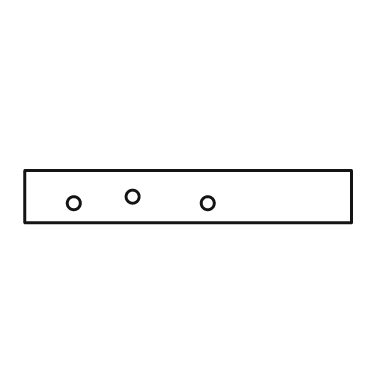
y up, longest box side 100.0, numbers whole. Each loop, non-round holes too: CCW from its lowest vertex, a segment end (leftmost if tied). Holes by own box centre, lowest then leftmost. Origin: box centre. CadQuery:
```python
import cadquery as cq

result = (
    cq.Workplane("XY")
    .moveTo(-50.0, -8.0)
    .lineTo(50.0, -8.0)
    .lineTo(50.0, 8.0)
    .lineTo(-50.0, 8.0)
    .close()
    .moveTo(-35.0, -2.0)
    .circle(2.0)
    .moveTo(6.0, -2.0)
    .circle(2.0)
    .moveTo(-17.0, 0.0)
    .circle(2.0)
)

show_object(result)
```